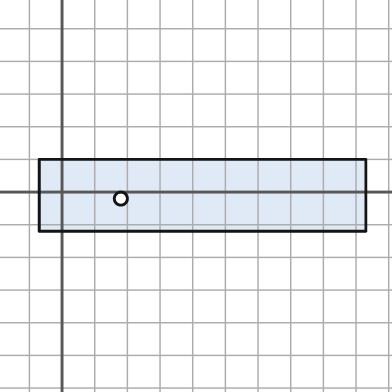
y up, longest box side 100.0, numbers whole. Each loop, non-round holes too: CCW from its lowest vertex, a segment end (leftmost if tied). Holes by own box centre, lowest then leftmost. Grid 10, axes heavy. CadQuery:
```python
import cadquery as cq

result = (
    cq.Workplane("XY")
    .moveTo(-7.0, -12.0)
    .lineTo(93.0, -12.0)
    .lineTo(93.0, 10.0)
    .lineTo(-7.0, 10.0)
    .close()
    .moveTo(18.0, -2.0)
    .circle(2.0)
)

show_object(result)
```